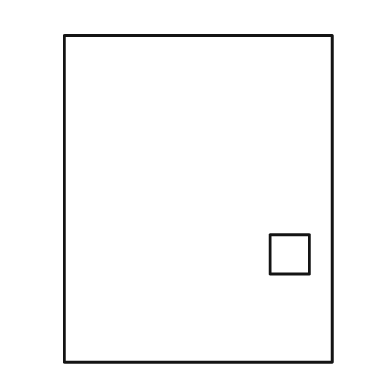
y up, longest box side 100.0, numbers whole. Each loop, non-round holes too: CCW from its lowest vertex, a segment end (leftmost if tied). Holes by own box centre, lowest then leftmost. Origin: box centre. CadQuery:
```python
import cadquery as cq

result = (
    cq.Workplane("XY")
    .moveTo(-41.0, -50.0)
    .lineTo(41.0, -50.0)
    .lineTo(41.0, 50.0)
    .lineTo(-41.0, 50.0)
    .close()
    .moveTo(22.0, -23.0)
    .lineTo(34.0, -23.0)
    .lineTo(34.0, -11.0)
    .lineTo(22.0, -11.0)
    .close()
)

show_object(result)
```